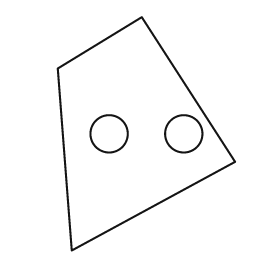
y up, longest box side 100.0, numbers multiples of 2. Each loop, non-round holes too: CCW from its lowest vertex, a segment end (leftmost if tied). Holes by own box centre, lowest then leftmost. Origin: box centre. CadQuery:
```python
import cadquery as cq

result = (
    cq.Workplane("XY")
    .moveTo(-32.0, -50.0)
    .lineTo(38.0, -12.0)
    .lineTo(-2.0, 50.0)
    .lineTo(-38.0, 28.0)
    .close()
    .moveTo(-16.0, 0.0)
    .circle(8.0)
    .moveTo(16.0, 0.0)
    .circle(8.0)
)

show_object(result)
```